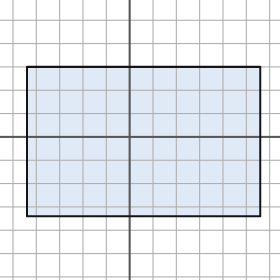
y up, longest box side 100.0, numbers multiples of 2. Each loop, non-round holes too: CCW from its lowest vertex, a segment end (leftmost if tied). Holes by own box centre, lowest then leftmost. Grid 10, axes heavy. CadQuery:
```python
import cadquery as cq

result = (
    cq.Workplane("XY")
    .moveTo(-44.0, -34.0)
    .lineTo(56.0, -34.0)
    .lineTo(56.0, 30.0)
    .lineTo(-44.0, 30.0)
    .close()
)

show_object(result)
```